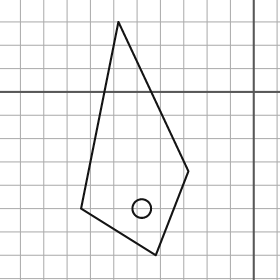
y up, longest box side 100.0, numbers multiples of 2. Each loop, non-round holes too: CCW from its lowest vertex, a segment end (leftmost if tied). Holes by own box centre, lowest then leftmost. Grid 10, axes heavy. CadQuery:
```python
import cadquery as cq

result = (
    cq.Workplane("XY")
    .moveTo(-42.0, -70.0)
    .lineTo(-28.0, -34.0)
    .lineTo(-58.0, 30.0)
    .lineTo(-74.0, -50.0)
    .close()
    .moveTo(-48.0, -50.0)
    .circle(4.0)
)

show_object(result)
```